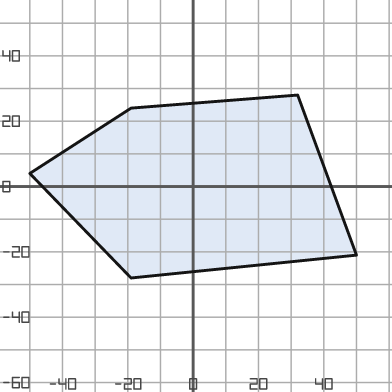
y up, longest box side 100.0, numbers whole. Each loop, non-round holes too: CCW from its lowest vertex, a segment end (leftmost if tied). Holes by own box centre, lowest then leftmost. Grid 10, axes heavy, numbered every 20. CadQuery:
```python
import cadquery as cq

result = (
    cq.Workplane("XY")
    .moveTo(-19.0, -28.0)
    .lineTo(50.0, -21.0)
    .lineTo(32.0, 28.0)
    .lineTo(-19.0, 24.0)
    .lineTo(-50.0, 4.0)
    .close()
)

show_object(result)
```